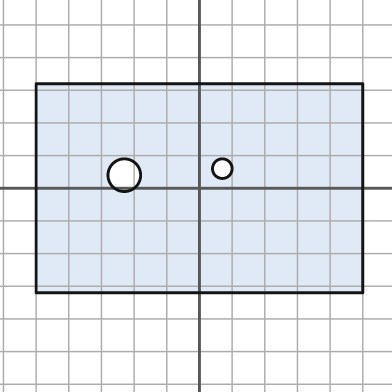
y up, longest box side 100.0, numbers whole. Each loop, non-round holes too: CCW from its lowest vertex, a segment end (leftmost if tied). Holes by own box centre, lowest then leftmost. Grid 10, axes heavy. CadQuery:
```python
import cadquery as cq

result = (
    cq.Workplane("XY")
    .moveTo(-50.0, -32.0)
    .lineTo(50.0, -32.0)
    .lineTo(50.0, 32.0)
    .lineTo(-50.0, 32.0)
    .close()
    .moveTo(-23.0, 4.0)
    .circle(5.0)
    .moveTo(7.0, 6.0)
    .circle(3.0)
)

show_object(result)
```